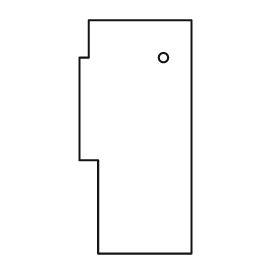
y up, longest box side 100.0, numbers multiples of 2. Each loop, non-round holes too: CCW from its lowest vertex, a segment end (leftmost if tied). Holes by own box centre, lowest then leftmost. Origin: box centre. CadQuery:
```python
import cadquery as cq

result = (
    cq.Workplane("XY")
    .moveTo(-16.0, -50.0)
    .lineTo(24.0, -50.0)
    .lineTo(24.0, 50.0)
    .lineTo(-20.0, 50.0)
    .lineTo(-20.0, 34.0)
    .lineTo(-24.0, 34.0)
    .lineTo(-24.0, -10.0)
    .lineTo(-16.0, -10.0)
    .close()
    .moveTo(12.0, 34.0)
    .circle(2.0)
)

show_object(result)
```